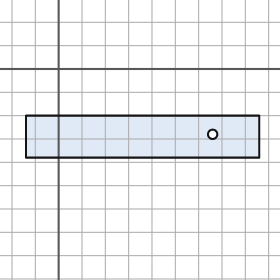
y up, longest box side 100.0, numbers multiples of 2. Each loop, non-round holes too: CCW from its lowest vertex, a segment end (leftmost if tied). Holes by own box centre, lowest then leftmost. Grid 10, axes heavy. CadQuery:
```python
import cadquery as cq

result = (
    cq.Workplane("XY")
    .moveTo(-14.0, -38.0)
    .lineTo(86.0, -38.0)
    .lineTo(86.0, -20.0)
    .lineTo(-14.0, -20.0)
    .close()
    .moveTo(66.0, -28.0)
    .circle(2.0)
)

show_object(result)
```